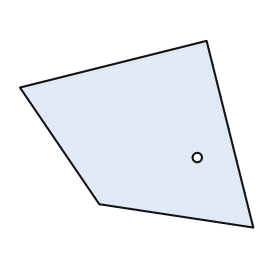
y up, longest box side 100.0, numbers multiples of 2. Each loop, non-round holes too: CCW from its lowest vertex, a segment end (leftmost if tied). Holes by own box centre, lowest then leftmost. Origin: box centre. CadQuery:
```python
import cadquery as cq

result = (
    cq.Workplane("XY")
    .moveTo(50.0, -40.0)
    .lineTo(30.0, 40.0)
    .lineTo(-50.0, 20.0)
    .lineTo(-16.0, -30.0)
    .close()
    .moveTo(26.0, -10.0)
    .circle(2.0)
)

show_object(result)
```